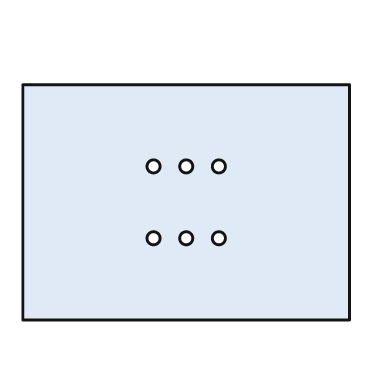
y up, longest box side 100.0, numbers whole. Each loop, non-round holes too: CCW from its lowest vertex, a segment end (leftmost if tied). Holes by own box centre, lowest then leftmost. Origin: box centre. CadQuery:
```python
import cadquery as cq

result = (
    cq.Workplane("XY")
    .moveTo(-50.0, -36.0)
    .lineTo(50.0, -36.0)
    .lineTo(50.0, 36.0)
    .lineTo(-50.0, 36.0)
    .close()
    .moveTo(-10.0, -11.0)
    .circle(2.0)
    .moveTo(0.0, -11.0)
    .circle(2.0)
    .moveTo(10.0, -11.0)
    .circle(2.0)
    .moveTo(-10.0, 11.0)
    .circle(2.0)
    .moveTo(0.0, 11.0)
    .circle(2.0)
    .moveTo(10.0, 11.0)
    .circle(2.0)
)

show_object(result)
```